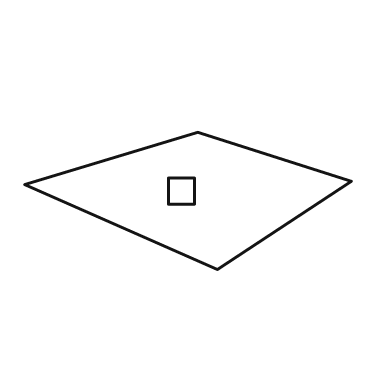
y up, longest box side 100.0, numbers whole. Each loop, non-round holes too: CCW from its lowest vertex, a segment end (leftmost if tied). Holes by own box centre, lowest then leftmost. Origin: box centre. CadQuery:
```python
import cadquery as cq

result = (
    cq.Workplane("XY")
    .moveTo(9.0, -21.0)
    .lineTo(50.0, 6.0)
    .lineTo(3.0, 21.0)
    .lineTo(-50.0, 5.0)
    .close()
    .moveTo(-6.0, -1.0)
    .lineTo(2.0, -1.0)
    .lineTo(2.0, 7.0)
    .lineTo(-6.0, 7.0)
    .close()
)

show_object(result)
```